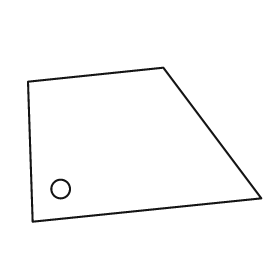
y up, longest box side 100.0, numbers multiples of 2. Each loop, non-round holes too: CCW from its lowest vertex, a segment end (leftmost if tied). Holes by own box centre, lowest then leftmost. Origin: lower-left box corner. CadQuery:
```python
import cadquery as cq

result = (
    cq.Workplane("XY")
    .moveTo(2.0, 0.0)
    .lineTo(100.0, 10.0)
    .lineTo(58.0, 66.0)
    .lineTo(0.0, 60.0)
    .close()
    .moveTo(14.0, 14.0)
    .circle(4.0)
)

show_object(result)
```